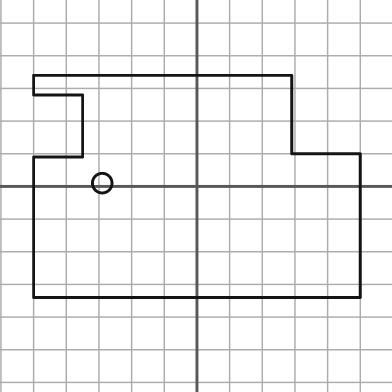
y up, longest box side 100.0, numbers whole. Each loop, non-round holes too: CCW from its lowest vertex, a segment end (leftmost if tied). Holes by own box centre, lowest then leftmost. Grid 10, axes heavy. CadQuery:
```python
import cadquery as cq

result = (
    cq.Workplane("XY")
    .moveTo(-50.0, -34.0)
    .lineTo(50.0, -34.0)
    .lineTo(50.0, 10.0)
    .lineTo(29.0, 10.0)
    .lineTo(29.0, 34.0)
    .lineTo(-50.0, 34.0)
    .lineTo(-50.0, 28.0)
    .lineTo(-35.0, 28.0)
    .lineTo(-35.0, 9.0)
    .lineTo(-50.0, 9.0)
    .close()
    .moveTo(-29.0, 1.0)
    .circle(3.0)
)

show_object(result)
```